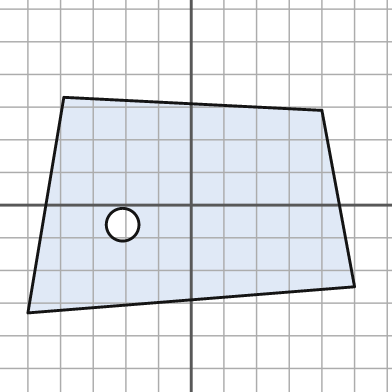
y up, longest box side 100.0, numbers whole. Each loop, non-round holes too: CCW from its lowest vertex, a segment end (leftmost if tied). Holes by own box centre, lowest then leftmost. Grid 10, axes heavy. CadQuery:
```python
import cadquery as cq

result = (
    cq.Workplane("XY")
    .moveTo(-50.0, -33.0)
    .lineTo(50.0, -25.0)
    .lineTo(40.0, 29.0)
    .lineTo(-39.0, 33.0)
    .close()
    .moveTo(-21.0, -6.0)
    .circle(5.0)
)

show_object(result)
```